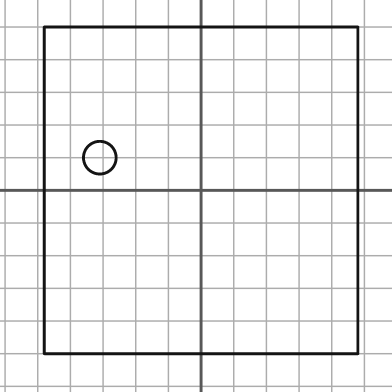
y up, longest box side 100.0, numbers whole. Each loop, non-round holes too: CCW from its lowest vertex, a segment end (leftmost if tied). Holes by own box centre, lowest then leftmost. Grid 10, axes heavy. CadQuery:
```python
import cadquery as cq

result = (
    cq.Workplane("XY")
    .moveTo(-48.0, -50.0)
    .lineTo(48.0, -50.0)
    .lineTo(48.0, 50.0)
    .lineTo(-48.0, 50.0)
    .close()
    .moveTo(-31.0, 10.0)
    .circle(5.0)
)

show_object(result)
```